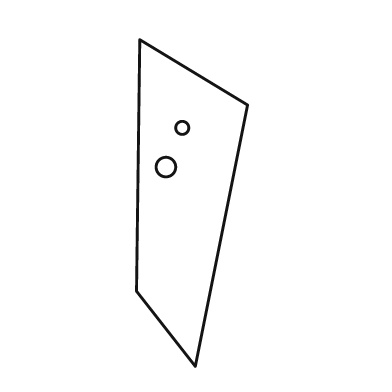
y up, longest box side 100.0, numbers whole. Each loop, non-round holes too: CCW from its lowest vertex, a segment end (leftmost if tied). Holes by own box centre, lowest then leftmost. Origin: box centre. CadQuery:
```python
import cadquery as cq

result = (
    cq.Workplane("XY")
    .moveTo(1.0, -50.0)
    .lineTo(17.0, 30.0)
    .lineTo(-16.0, 50.0)
    .lineTo(-17.0, -27.0)
    .close()
    .moveTo(-8.0, 11.0)
    .circle(3.0)
    .moveTo(-3.0, 23.0)
    .circle(2.0)
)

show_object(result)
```